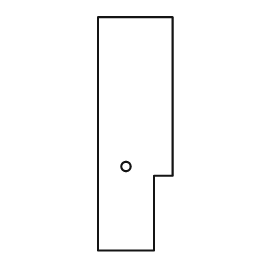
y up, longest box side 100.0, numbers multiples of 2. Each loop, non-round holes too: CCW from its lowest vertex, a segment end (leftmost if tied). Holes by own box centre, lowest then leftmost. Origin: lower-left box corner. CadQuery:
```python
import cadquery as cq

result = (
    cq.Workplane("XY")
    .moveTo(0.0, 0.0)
    .lineTo(24.0, 0.0)
    .lineTo(24.0, 32.0)
    .lineTo(32.0, 32.0)
    .lineTo(32.0, 100.0)
    .lineTo(0.0, 100.0)
    .close()
    .moveTo(12.0, 36.0)
    .circle(2.0)
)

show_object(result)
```